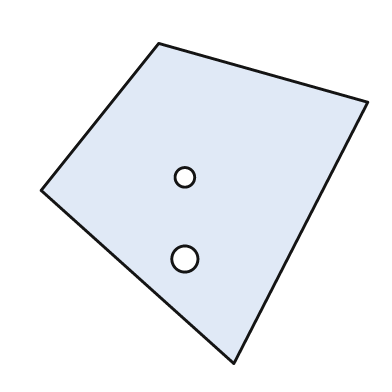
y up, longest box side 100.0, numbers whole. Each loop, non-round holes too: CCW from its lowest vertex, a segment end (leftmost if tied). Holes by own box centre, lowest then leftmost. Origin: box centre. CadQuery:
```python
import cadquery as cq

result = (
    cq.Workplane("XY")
    .moveTo(9.0, -49.0)
    .lineTo(50.0, 31.0)
    .lineTo(-14.0, 49.0)
    .lineTo(-50.0, 4.0)
    .close()
    .moveTo(-6.0, -17.0)
    .circle(4.0)
    .moveTo(-6.0, 8.0)
    .circle(3.0)
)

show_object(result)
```